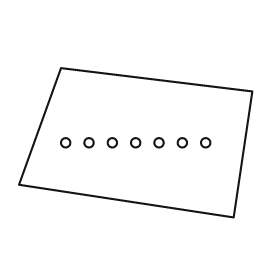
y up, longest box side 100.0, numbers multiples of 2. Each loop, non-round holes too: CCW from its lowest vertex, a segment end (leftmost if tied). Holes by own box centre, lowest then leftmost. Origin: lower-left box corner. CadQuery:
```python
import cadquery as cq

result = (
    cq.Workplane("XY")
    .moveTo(92.0, 0.0)
    .lineTo(100.0, 54.0)
    .lineTo(18.0, 64.0)
    .lineTo(0.0, 14.0)
    .close()
    .moveTo(20.0, 32.0)
    .circle(2.0)
    .moveTo(30.0, 32.0)
    .circle(2.0)
    .moveTo(40.0, 32.0)
    .circle(2.0)
    .moveTo(50.0, 32.0)
    .circle(2.0)
    .moveTo(60.0, 32.0)
    .circle(2.0)
    .moveTo(70.0, 32.0)
    .circle(2.0)
    .moveTo(80.0, 32.0)
    .circle(2.0)
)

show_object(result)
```